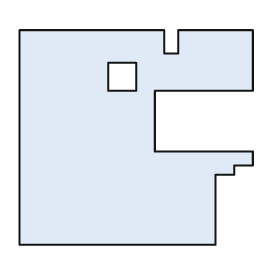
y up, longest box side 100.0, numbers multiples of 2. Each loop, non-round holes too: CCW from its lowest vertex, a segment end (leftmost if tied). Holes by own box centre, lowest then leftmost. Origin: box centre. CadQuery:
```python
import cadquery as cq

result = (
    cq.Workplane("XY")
    .moveTo(-50.0, -46.0)
    .lineTo(34.0, -46.0)
    .lineTo(34.0, -16.0)
    .lineTo(42.0, -16.0)
    .lineTo(42.0, -12.0)
    .lineTo(50.0, -12.0)
    .lineTo(50.0, -6.0)
    .lineTo(8.0, -6.0)
    .lineTo(8.0, 20.0)
    .lineTo(50.0, 20.0)
    .lineTo(50.0, 46.0)
    .lineTo(18.0, 46.0)
    .lineTo(18.0, 36.0)
    .lineTo(12.0, 36.0)
    .lineTo(12.0, 46.0)
    .lineTo(-50.0, 46.0)
    .close()
    .moveTo(-12.0, 20.0)
    .lineTo(0.0, 20.0)
    .lineTo(0.0, 32.0)
    .lineTo(-12.0, 32.0)
    .close()
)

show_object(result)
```